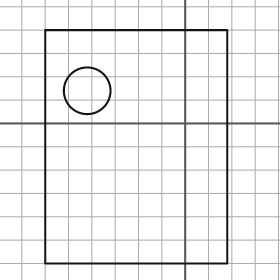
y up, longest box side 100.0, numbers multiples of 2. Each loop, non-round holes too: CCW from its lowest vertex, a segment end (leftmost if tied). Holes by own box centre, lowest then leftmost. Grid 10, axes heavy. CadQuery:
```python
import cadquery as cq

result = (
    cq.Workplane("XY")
    .moveTo(-60.0, -60.0)
    .lineTo(18.0, -60.0)
    .lineTo(18.0, 40.0)
    .lineTo(-60.0, 40.0)
    .close()
    .moveTo(-42.0, 14.0)
    .circle(10.0)
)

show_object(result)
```